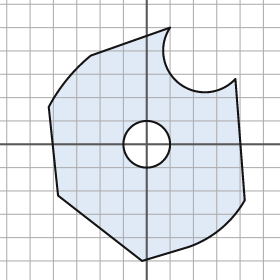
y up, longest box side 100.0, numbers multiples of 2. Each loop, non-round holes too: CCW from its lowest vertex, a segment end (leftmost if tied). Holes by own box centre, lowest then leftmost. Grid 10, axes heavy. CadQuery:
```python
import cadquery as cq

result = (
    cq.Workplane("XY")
    .moveTo(-2.0, -50.0)
    .lineTo(18.0, -44.0)
    .threePointArc((32.0, -36.0), (42.0, -24.0))
    .lineTo(38.0, 28.0)
    .threePointArc((14.0, 26.0), (10.0, 50.0))
    .lineTo(-24.0, 38.0)
    .threePointArc((-34.0, 28.0), (-42.0, 16.0))
    .lineTo(-38.0, -22.0)
    .close()
    .moveTo(0.0, 0.0)
    .circle(10.0)
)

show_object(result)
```